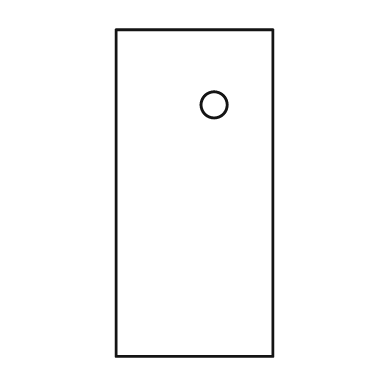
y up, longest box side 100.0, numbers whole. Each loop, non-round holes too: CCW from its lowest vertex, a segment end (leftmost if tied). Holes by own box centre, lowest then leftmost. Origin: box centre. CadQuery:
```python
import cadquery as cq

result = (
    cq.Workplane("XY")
    .moveTo(-24.0, -50.0)
    .lineTo(24.0, -50.0)
    .lineTo(24.0, 50.0)
    .lineTo(-24.0, 50.0)
    .close()
    .moveTo(6.0, 27.0)
    .circle(4.0)
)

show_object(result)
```